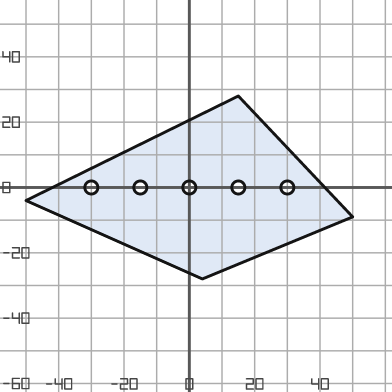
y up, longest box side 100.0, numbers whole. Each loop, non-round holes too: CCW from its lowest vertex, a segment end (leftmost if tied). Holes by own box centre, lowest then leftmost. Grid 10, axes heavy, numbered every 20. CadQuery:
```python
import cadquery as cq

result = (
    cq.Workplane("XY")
    .moveTo(4.0, -28.0)
    .lineTo(50.0, -9.0)
    .lineTo(15.0, 28.0)
    .lineTo(-50.0, -4.0)
    .close()
    .moveTo(-30.0, 0.0)
    .circle(2.0)
    .moveTo(-15.0, 0.0)
    .circle(2.0)
    .moveTo(0.0, 0.0)
    .circle(2.0)
    .moveTo(15.0, 0.0)
    .circle(2.0)
    .moveTo(30.0, 0.0)
    .circle(2.0)
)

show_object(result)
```